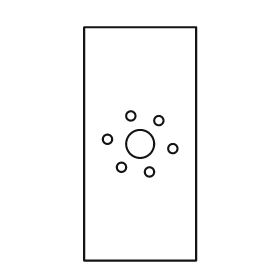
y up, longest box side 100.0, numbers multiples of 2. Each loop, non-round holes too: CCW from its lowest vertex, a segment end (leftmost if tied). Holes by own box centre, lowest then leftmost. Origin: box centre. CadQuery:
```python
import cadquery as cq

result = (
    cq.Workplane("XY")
    .moveTo(-24.0, -50.0)
    .lineTo(24.0, -50.0)
    .lineTo(24.0, 50.0)
    .lineTo(-24.0, 50.0)
    .close()
    .moveTo(4.0, -12.0)
    .circle(2.0)
    .moveTo(-8.0, -10.0)
    .circle(2.0)
    .moveTo(14.0, -2.0)
    .circle(2.0)
    .moveTo(0.0, 0.0)
    .circle(6.0)
    .moveTo(-14.0, 2.0)
    .circle(2.0)
    .moveTo(8.0, 10.0)
    .circle(2.0)
    .moveTo(-4.0, 12.0)
    .circle(2.0)
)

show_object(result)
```